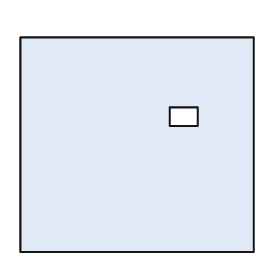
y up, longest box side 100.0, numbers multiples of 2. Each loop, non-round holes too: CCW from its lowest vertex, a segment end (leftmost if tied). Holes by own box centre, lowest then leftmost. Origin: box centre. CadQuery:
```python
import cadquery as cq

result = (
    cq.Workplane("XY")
    .moveTo(-50.0, -46.0)
    .lineTo(50.0, -46.0)
    .lineTo(50.0, 46.0)
    .lineTo(-50.0, 46.0)
    .close()
    .moveTo(14.0, 8.0)
    .lineTo(26.0, 8.0)
    .lineTo(26.0, 16.0)
    .lineTo(14.0, 16.0)
    .close()
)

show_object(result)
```